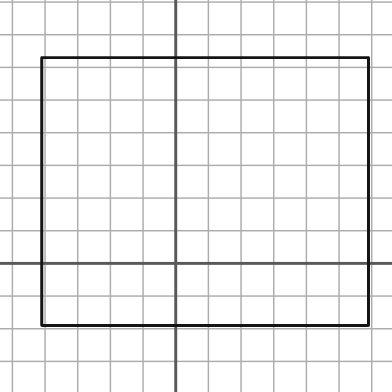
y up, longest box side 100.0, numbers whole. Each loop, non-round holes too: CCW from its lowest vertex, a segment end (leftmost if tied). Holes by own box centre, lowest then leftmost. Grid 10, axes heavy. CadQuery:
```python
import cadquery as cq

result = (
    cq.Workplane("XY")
    .moveTo(-41.0, -19.0)
    .lineTo(59.0, -19.0)
    .lineTo(59.0, 63.0)
    .lineTo(-41.0, 63.0)
    .close()
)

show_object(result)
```